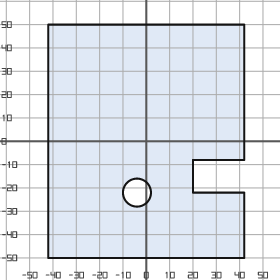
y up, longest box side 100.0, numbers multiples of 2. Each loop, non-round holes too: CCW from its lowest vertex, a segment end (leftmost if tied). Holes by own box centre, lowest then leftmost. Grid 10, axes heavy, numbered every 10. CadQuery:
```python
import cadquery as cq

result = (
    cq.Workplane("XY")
    .moveTo(-42.0, -50.0)
    .lineTo(42.0, -50.0)
    .lineTo(42.0, -22.0)
    .lineTo(20.0, -22.0)
    .lineTo(20.0, -8.0)
    .lineTo(42.0, -8.0)
    .lineTo(42.0, 50.0)
    .lineTo(-42.0, 50.0)
    .close()
    .moveTo(-4.0, -22.0)
    .circle(6.0)
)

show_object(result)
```